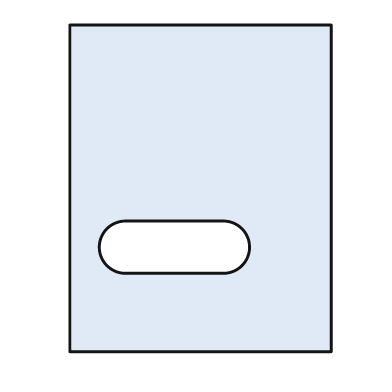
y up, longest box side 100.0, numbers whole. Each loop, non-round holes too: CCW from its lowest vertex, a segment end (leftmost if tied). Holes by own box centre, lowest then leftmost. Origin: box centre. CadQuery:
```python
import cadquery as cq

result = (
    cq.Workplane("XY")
    .moveTo(-40.0, -50.0)
    .lineTo(40.0, -50.0)
    .lineTo(40.0, 50.0)
    .lineTo(-40.0, 50.0)
    .close()
    .moveTo(-23.0, -26.0)
    .lineTo(7.0, -26.0)
    .threePointArc((15.0, -18.0), (7.0, -10.0))
    .lineTo(-23.0, -10.0)
    .threePointArc((-31.0, -18.0), (-23.0, -26.0))
    .close()
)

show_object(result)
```